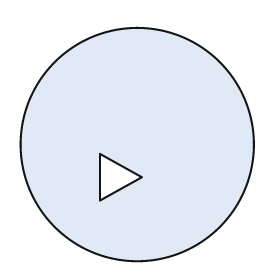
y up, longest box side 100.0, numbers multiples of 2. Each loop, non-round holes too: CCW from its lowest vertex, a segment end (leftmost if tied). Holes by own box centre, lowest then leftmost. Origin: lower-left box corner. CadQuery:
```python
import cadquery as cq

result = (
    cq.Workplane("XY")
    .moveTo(50.0, 50.0)
    .circle(50.0)
    .moveTo(34.0, 26.0)
    .lineTo(52.0, 36.0)
    .lineTo(34.0, 46.0)
    .close()
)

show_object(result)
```